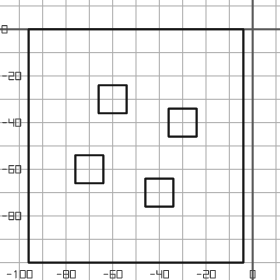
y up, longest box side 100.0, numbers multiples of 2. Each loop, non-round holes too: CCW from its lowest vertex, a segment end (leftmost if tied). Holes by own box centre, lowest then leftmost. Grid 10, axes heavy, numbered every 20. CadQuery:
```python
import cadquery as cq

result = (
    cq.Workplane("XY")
    .moveTo(-96.0, -100.0)
    .lineTo(-4.0, -100.0)
    .lineTo(-4.0, 0.0)
    .lineTo(-96.0, 0.0)
    .close()
    .moveTo(-46.0, -76.0)
    .lineTo(-34.0, -76.0)
    .lineTo(-34.0, -64.0)
    .lineTo(-46.0, -64.0)
    .close()
    .moveTo(-76.0, -66.0)
    .lineTo(-64.0, -66.0)
    .lineTo(-64.0, -54.0)
    .lineTo(-76.0, -54.0)
    .close()
    .moveTo(-36.0, -46.0)
    .lineTo(-24.0, -46.0)
    .lineTo(-24.0, -34.0)
    .lineTo(-36.0, -34.0)
    .close()
    .moveTo(-66.0, -36.0)
    .lineTo(-54.0, -36.0)
    .lineTo(-54.0, -24.0)
    .lineTo(-66.0, -24.0)
    .close()
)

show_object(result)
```